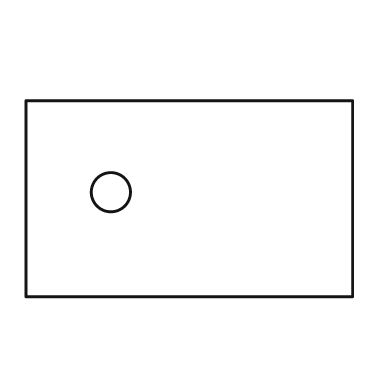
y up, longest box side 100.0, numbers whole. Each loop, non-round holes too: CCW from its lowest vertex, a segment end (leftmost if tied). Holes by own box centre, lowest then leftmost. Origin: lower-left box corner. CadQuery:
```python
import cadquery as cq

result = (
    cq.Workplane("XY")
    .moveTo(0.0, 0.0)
    .lineTo(100.0, 0.0)
    .lineTo(100.0, 60.0)
    .lineTo(0.0, 60.0)
    .close()
    .moveTo(26.0, 32.0)
    .circle(6.0)
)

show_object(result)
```